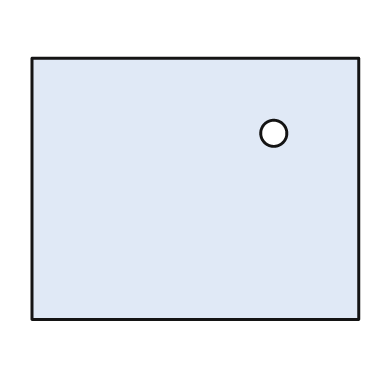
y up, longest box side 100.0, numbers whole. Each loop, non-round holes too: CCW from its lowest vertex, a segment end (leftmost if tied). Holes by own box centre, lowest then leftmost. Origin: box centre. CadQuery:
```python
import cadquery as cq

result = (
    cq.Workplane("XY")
    .moveTo(-50.0, -40.0)
    .lineTo(50.0, -40.0)
    .lineTo(50.0, 40.0)
    .lineTo(-50.0, 40.0)
    .close()
    .moveTo(24.0, 17.0)
    .circle(4.0)
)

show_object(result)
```